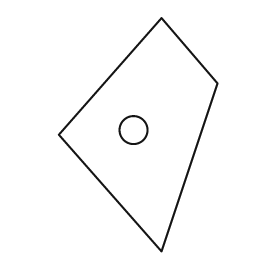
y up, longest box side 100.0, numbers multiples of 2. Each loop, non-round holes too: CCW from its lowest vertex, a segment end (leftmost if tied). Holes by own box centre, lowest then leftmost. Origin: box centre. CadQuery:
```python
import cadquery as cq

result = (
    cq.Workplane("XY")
    .moveTo(10.0, -50.0)
    .lineTo(34.0, 22.0)
    .lineTo(10.0, 50.0)
    .lineTo(-34.0, 0.0)
    .close()
    .moveTo(-2.0, 2.0)
    .circle(6.0)
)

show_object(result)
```